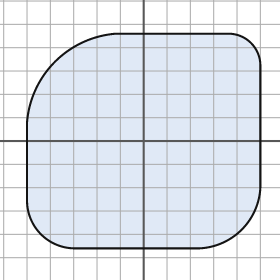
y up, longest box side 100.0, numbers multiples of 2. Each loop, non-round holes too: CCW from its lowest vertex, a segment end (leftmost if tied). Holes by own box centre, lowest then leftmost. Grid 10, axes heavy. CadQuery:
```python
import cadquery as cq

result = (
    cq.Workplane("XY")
    .moveTo(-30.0, -46.0)
    .lineTo(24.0, -46.0)
    .threePointArc((42.0, -38.0), (50.0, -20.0))
    .lineTo(50.0, 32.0)
    .threePointArc((46.0, 42.0), (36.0, 46.0))
    .lineTo(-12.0, 46.0)
    .threePointArc((-38.0, 34.0), (-50.0, 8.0))
    .lineTo(-50.0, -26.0)
    .threePointArc((-44.0, -40.0), (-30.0, -46.0))
    .close()
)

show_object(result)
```